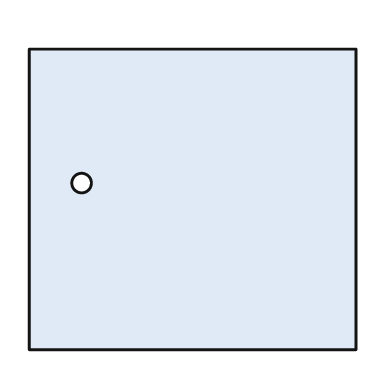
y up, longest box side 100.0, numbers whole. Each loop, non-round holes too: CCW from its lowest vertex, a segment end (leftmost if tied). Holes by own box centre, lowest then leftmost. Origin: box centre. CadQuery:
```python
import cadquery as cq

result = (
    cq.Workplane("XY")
    .moveTo(-50.0, -46.0)
    .lineTo(50.0, -46.0)
    .lineTo(50.0, 46.0)
    .lineTo(-50.0, 46.0)
    .close()
    .moveTo(-34.0, 5.0)
    .circle(3.0)
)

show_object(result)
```